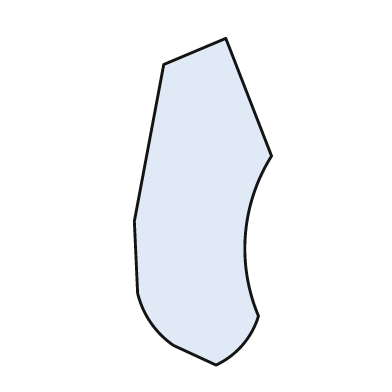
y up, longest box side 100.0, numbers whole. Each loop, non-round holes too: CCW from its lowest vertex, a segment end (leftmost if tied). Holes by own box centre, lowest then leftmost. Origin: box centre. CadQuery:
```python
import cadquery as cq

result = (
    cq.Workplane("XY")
    .moveTo(4.0, -50.0)
    .threePointArc((12.0, -44.0), (17.0, -35.0))
    .threePointArc((13.0, -10.0), (21.0, 14.0))
    .lineTo(7.0, 50.0)
    .lineTo(-12.0, 42.0)
    .lineTo(-21.0, -6.0)
    .lineTo(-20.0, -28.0)
    .threePointArc((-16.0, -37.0), (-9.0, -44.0))
    .close()
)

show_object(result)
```